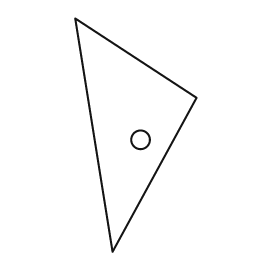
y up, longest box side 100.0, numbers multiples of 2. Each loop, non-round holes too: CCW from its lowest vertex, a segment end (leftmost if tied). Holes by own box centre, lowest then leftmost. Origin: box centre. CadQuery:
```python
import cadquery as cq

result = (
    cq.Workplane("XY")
    .moveTo(-10.0, -50.0)
    .lineTo(26.0, 16.0)
    .lineTo(-26.0, 50.0)
    .close()
    .moveTo(2.0, -2.0)
    .circle(4.0)
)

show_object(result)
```